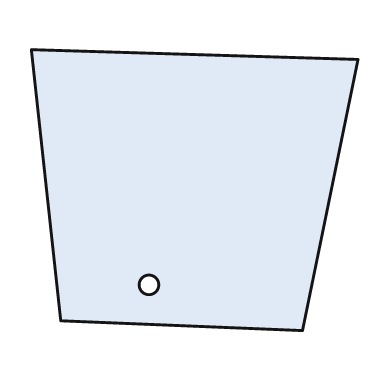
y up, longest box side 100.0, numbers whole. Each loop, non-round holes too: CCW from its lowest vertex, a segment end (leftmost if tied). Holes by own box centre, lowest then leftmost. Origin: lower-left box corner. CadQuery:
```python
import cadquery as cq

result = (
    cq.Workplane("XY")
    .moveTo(83.0, 0.0)
    .lineTo(100.0, 83.0)
    .lineTo(0.0, 86.0)
    .lineTo(9.0, 3.0)
    .close()
    .moveTo(36.0, 14.0)
    .circle(3.0)
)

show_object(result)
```